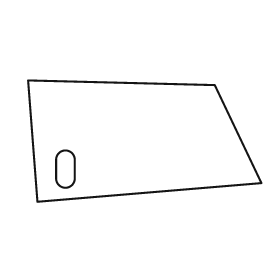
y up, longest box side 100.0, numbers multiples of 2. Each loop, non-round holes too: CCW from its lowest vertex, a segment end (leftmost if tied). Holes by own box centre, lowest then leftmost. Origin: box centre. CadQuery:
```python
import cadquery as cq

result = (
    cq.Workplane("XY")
    .moveTo(-46.0, -26.0)
    .lineTo(50.0, -18.0)
    .lineTo(30.0, 24.0)
    .lineTo(-50.0, 26.0)
    .close()
    .moveTo(-38.0, -16.0)
    .threePointArc((-34.0, -20.0), (-30.0, -16.0))
    .lineTo(-30.0, -8.0)
    .threePointArc((-34.0, -4.0), (-38.0, -8.0))
    .close()
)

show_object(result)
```